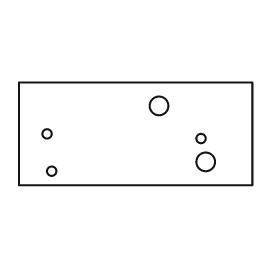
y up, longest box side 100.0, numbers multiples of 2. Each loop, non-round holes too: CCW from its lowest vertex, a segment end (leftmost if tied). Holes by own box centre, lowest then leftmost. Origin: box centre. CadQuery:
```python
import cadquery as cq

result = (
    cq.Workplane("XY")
    .moveTo(-50.0, -22.0)
    .lineTo(50.0, -22.0)
    .lineTo(50.0, 22.0)
    .lineTo(-50.0, 22.0)
    .close()
    .moveTo(-36.0, -16.0)
    .circle(2.0)
    .moveTo(30.0, -12.0)
    .circle(4.0)
    .moveTo(28.0, -2.0)
    .circle(2.0)
    .moveTo(-38.0, 0.0)
    .circle(2.0)
    .moveTo(10.0, 12.0)
    .circle(4.0)
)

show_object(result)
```